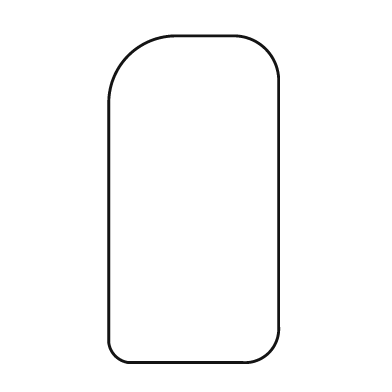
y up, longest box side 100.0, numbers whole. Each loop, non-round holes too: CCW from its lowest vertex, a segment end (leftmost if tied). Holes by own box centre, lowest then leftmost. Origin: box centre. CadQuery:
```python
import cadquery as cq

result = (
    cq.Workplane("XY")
    .moveTo(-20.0, -50.0)
    .lineTo(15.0, -50.0)
    .threePointArc((23.0, -47.0), (26.0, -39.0))
    .lineTo(26.0, 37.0)
    .threePointArc((22.0, 46.0), (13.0, 50.0))
    .lineTo(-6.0, 50.0)
    .threePointArc((-20.0, 44.0), (-26.0, 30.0))
    .lineTo(-26.0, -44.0)
    .threePointArc((-24.0, -48.0), (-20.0, -50.0))
    .close()
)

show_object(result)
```